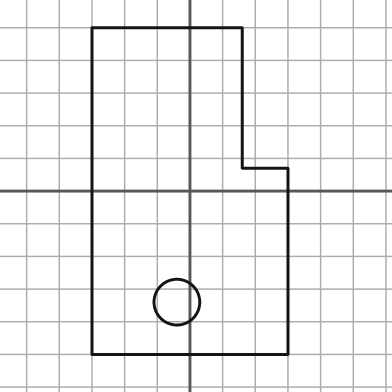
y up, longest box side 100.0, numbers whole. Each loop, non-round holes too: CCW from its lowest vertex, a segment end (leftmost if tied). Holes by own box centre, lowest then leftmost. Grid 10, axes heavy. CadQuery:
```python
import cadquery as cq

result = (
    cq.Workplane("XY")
    .moveTo(-30.0, -50.0)
    .lineTo(30.0, -50.0)
    .lineTo(30.0, 7.0)
    .lineTo(16.0, 7.0)
    .lineTo(16.0, 50.0)
    .lineTo(-30.0, 50.0)
    .close()
    .moveTo(-4.0, -34.0)
    .circle(7.0)
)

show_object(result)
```